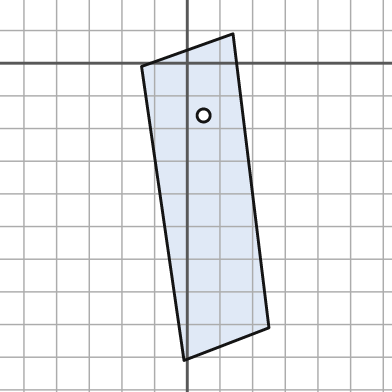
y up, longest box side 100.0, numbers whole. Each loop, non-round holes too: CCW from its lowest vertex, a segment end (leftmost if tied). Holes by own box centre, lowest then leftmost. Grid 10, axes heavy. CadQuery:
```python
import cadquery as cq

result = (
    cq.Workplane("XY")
    .moveTo(-1.0, -91.0)
    .lineTo(25.0, -81.0)
    .lineTo(14.0, 9.0)
    .lineTo(-14.0, -1.0)
    .close()
    .moveTo(5.0, -16.0)
    .circle(2.0)
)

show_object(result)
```